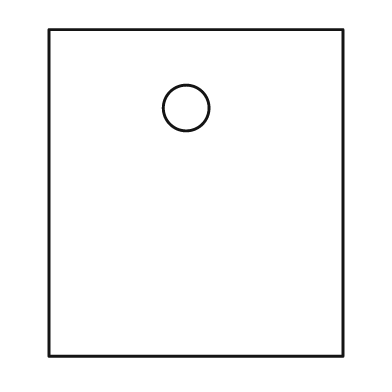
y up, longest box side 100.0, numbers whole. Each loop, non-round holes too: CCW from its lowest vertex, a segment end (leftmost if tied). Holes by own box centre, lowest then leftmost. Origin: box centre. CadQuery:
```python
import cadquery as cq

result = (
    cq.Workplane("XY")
    .moveTo(-45.0, -50.0)
    .lineTo(45.0, -50.0)
    .lineTo(45.0, 50.0)
    .lineTo(-45.0, 50.0)
    .close()
    .moveTo(-3.0, 26.0)
    .circle(7.0)
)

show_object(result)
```